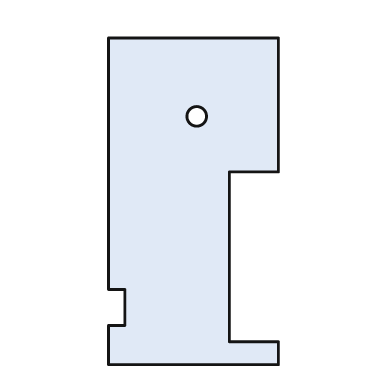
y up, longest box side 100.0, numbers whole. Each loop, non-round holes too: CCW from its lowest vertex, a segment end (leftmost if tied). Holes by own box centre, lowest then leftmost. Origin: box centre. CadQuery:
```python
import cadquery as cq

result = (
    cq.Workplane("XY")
    .moveTo(-26.0, -50.0)
    .lineTo(26.0, -50.0)
    .lineTo(26.0, -43.0)
    .lineTo(11.0, -43.0)
    .lineTo(11.0, 9.0)
    .lineTo(26.0, 9.0)
    .lineTo(26.0, 50.0)
    .lineTo(-26.0, 50.0)
    .lineTo(-26.0, -27.0)
    .lineTo(-21.0, -27.0)
    .lineTo(-21.0, -38.0)
    .lineTo(-26.0, -38.0)
    .close()
    .moveTo(1.0, 26.0)
    .circle(3.0)
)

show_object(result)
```